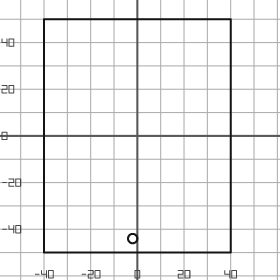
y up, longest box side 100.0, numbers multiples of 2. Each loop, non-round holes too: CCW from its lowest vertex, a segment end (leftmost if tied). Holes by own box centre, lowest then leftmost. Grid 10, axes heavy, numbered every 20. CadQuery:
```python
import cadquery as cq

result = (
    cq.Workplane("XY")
    .moveTo(-40.0, -50.0)
    .lineTo(40.0, -50.0)
    .lineTo(40.0, 50.0)
    .lineTo(-40.0, 50.0)
    .close()
    .moveTo(-2.0, -44.0)
    .circle(2.0)
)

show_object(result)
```